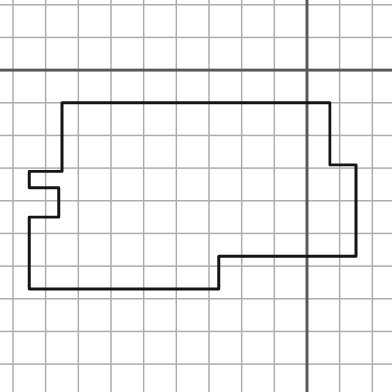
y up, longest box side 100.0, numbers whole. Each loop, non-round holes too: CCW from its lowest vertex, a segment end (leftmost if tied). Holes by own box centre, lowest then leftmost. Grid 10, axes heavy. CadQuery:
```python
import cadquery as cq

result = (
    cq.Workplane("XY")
    .moveTo(-85.0, -67.0)
    .lineTo(-27.0, -67.0)
    .lineTo(-27.0, -57.0)
    .lineTo(15.0, -57.0)
    .lineTo(15.0, -29.0)
    .lineTo(7.0, -29.0)
    .lineTo(7.0, -10.0)
    .lineTo(-75.0, -10.0)
    .lineTo(-75.0, -31.0)
    .lineTo(-85.0, -31.0)
    .lineTo(-85.0, -36.0)
    .lineTo(-76.0, -36.0)
    .lineTo(-76.0, -45.0)
    .lineTo(-85.0, -45.0)
    .close()
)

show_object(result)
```